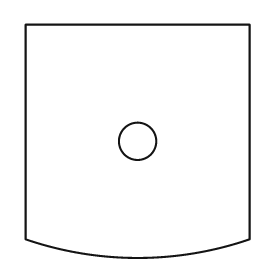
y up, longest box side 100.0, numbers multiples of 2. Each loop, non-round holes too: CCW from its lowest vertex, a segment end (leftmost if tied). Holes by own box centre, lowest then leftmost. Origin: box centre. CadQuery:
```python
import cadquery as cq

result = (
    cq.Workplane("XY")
    .moveTo(-48.0, -42.0)
    .threePointArc((0.0, -50.0), (48.0, -42.0))
    .lineTo(48.0, 50.0)
    .lineTo(-48.0, 50.0)
    .close()
    .moveTo(0.0, 0.0)
    .circle(8.0)
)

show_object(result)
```